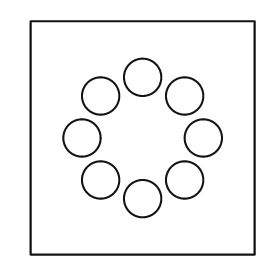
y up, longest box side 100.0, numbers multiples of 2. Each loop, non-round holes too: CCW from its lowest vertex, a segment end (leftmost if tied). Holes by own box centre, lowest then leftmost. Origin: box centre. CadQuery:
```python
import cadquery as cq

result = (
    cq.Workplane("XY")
    .moveTo(-48.0, -50.0)
    .lineTo(48.0, -50.0)
    .lineTo(48.0, 50.0)
    .lineTo(-48.0, 50.0)
    .close()
    .moveTo(0.0, -26.0)
    .circle(8.0)
    .moveTo(-18.0, -18.0)
    .circle(8.0)
    .moveTo(18.0, -18.0)
    .circle(8.0)
    .moveTo(-26.0, 0.0)
    .circle(8.0)
    .moveTo(26.0, 0.0)
    .circle(8.0)
    .moveTo(-18.0, 18.0)
    .circle(8.0)
    .moveTo(18.0, 18.0)
    .circle(8.0)
    .moveTo(0.0, 26.0)
    .circle(8.0)
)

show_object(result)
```